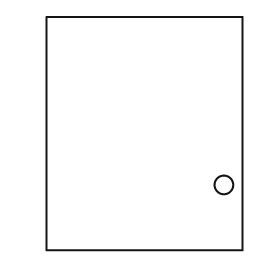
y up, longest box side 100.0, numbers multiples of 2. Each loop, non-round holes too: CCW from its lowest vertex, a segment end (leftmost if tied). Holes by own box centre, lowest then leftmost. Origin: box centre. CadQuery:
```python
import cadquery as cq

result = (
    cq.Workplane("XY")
    .moveTo(-42.0, -50.0)
    .lineTo(42.0, -50.0)
    .lineTo(42.0, 50.0)
    .lineTo(-42.0, 50.0)
    .close()
    .moveTo(34.0, -22.0)
    .circle(4.0)
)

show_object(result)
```